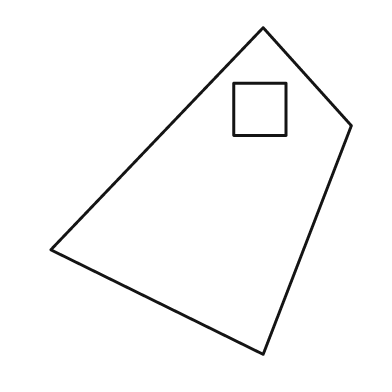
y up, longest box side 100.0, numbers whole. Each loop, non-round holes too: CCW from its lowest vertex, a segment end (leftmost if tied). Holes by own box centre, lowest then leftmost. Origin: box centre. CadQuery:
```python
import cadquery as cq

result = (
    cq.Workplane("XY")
    .moveTo(19.0, -50.0)
    .lineTo(46.0, 20.0)
    .lineTo(19.0, 50.0)
    .lineTo(-46.0, -18.0)
    .close()
    .moveTo(10.0, 17.0)
    .lineTo(26.0, 17.0)
    .lineTo(26.0, 33.0)
    .lineTo(10.0, 33.0)
    .close()
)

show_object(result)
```